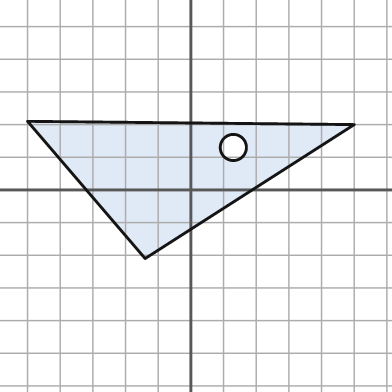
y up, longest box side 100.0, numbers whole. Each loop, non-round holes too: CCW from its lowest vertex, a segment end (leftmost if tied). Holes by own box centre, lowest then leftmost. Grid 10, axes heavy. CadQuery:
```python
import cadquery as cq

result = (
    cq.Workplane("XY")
    .moveTo(-14.0, -21.0)
    .lineTo(50.0, 20.0)
    .lineTo(-50.0, 21.0)
    .close()
    .moveTo(13.0, 13.0)
    .circle(4.0)
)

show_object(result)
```